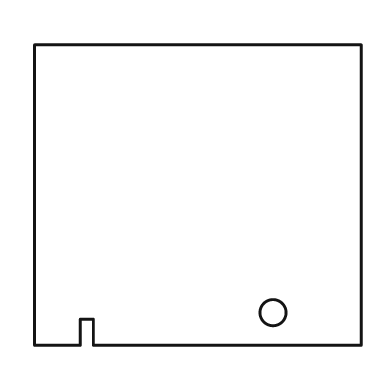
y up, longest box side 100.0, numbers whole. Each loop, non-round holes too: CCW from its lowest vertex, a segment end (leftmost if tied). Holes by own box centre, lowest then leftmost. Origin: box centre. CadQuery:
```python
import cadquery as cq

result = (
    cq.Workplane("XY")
    .moveTo(-50.0, -46.0)
    .lineTo(-36.0, -46.0)
    .lineTo(-36.0, -38.0)
    .lineTo(-32.0, -38.0)
    .lineTo(-32.0, -46.0)
    .lineTo(50.0, -46.0)
    .lineTo(50.0, 46.0)
    .lineTo(-50.0, 46.0)
    .close()
    .moveTo(23.0, -36.0)
    .circle(4.0)
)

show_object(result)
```